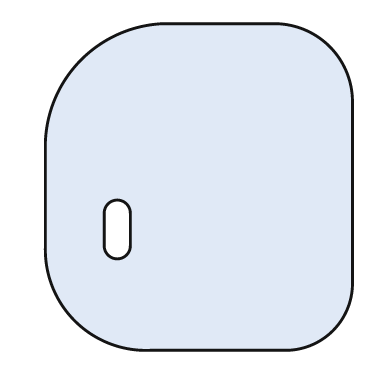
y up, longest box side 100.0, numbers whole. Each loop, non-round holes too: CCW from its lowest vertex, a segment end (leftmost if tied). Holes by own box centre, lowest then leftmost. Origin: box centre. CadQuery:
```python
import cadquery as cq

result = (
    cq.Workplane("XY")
    .moveTo(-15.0, -50.0)
    .lineTo(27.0, -50.0)
    .threePointArc((41.0, -44.0), (47.0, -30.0))
    .lineTo(47.0, 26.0)
    .threePointArc((40.0, 43.0), (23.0, 50.0))
    .lineTo(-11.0, 50.0)
    .threePointArc((-36.0, 39.0), (-47.0, 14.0))
    .lineTo(-47.0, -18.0)
    .threePointArc((-38.0, -41.0), (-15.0, -50.0))
    .close()
    .moveTo(-29.0, -18.0)
    .threePointArc((-25.0, -22.0), (-21.0, -18.0))
    .lineTo(-21.0, -8.0)
    .threePointArc((-25.0, -4.0), (-29.0, -8.0))
    .close()
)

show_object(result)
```